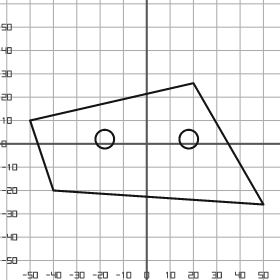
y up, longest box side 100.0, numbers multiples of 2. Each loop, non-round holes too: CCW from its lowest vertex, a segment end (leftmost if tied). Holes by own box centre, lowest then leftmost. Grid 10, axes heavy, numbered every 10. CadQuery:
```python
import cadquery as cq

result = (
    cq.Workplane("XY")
    .moveTo(50.0, -26.0)
    .lineTo(20.0, 26.0)
    .lineTo(-50.0, 10.0)
    .lineTo(-40.0, -20.0)
    .close()
    .moveTo(-18.0, 2.0)
    .circle(4.0)
    .moveTo(18.0, 2.0)
    .circle(4.0)
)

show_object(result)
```